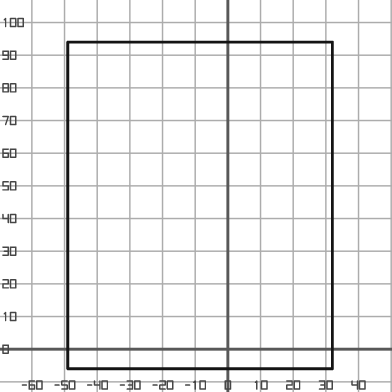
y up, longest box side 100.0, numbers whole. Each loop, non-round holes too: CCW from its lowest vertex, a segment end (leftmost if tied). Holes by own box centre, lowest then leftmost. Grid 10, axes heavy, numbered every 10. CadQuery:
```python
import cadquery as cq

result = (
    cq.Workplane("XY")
    .moveTo(-49.0, -6.0)
    .lineTo(32.0, -6.0)
    .lineTo(32.0, 94.0)
    .lineTo(-49.0, 94.0)
    .close()
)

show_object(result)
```